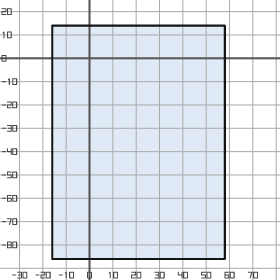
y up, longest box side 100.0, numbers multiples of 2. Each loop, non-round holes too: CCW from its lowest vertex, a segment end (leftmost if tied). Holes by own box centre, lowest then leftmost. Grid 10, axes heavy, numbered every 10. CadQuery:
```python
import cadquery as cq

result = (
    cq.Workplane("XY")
    .moveTo(-16.0, -86.0)
    .lineTo(58.0, -86.0)
    .lineTo(58.0, 14.0)
    .lineTo(-16.0, 14.0)
    .close()
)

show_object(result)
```